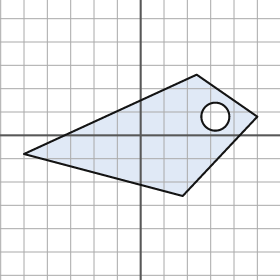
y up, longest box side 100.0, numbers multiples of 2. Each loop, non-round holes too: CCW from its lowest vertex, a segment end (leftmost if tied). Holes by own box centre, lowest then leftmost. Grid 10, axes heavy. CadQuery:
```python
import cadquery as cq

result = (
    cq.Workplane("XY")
    .moveTo(18.0, -26.0)
    .lineTo(50.0, 8.0)
    .lineTo(24.0, 26.0)
    .lineTo(-50.0, -8.0)
    .close()
    .moveTo(32.0, 8.0)
    .circle(6.0)
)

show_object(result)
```